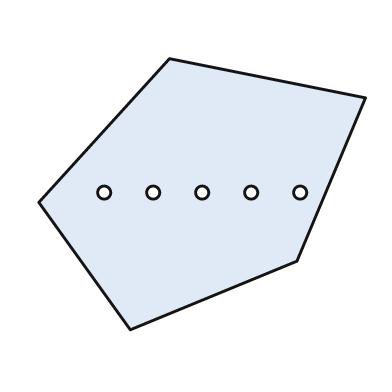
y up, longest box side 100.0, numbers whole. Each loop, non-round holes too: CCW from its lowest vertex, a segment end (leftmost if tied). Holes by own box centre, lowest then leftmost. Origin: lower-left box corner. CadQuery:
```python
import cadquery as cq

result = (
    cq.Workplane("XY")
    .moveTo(28.0, 0.0)
    .lineTo(79.0, 21.0)
    .lineTo(100.0, 71.0)
    .lineTo(40.0, 83.0)
    .lineTo(0.0, 39.0)
    .close()
    .moveTo(20.0, 42.0)
    .circle(2.0)
    .moveTo(35.0, 42.0)
    .circle(2.0)
    .moveTo(50.0, 42.0)
    .circle(2.0)
    .moveTo(65.0, 42.0)
    .circle(2.0)
    .moveTo(80.0, 42.0)
    .circle(2.0)
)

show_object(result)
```